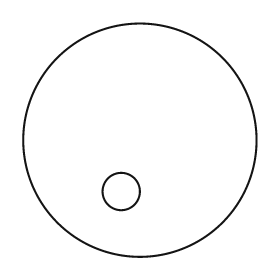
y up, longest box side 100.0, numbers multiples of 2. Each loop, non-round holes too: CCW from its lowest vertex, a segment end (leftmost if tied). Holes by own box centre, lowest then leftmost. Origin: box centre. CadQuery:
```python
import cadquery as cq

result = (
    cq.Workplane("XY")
    .moveTo(0.0, 0.0)
    .circle(50.0)
    .moveTo(-8.0, -22.0)
    .circle(8.0)
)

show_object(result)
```